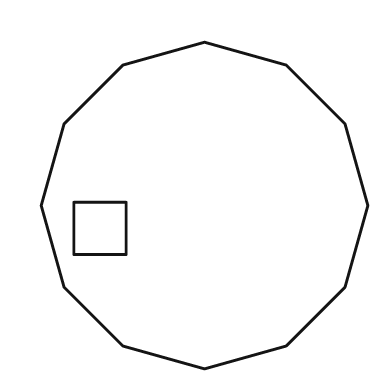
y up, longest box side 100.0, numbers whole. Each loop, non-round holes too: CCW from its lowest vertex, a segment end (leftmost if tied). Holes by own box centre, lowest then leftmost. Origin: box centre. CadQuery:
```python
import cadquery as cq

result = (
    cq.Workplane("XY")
    .moveTo(0.0, -50.0)
    .lineTo(25.0, -43.0)
    .lineTo(43.0, -25.0)
    .lineTo(50.0, 0.0)
    .lineTo(43.0, 25.0)
    .lineTo(25.0, 43.0)
    .lineTo(0.0, 50.0)
    .lineTo(-25.0, 43.0)
    .lineTo(-43.0, 25.0)
    .lineTo(-50.0, 0.0)
    .lineTo(-43.0, -25.0)
    .lineTo(-25.0, -43.0)
    .close()
    .moveTo(-40.0, -15.0)
    .lineTo(-24.0, -15.0)
    .lineTo(-24.0, 1.0)
    .lineTo(-40.0, 1.0)
    .close()
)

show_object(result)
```